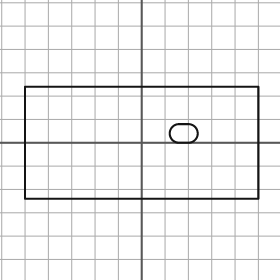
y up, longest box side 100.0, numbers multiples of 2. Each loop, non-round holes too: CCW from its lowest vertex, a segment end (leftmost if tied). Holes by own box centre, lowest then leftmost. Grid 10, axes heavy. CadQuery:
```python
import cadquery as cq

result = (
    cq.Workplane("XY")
    .moveTo(-50.0, -24.0)
    .lineTo(50.0, -24.0)
    .lineTo(50.0, 24.0)
    .lineTo(-50.0, 24.0)
    .close()
    .moveTo(16.0, 0.0)
    .lineTo(20.0, 0.0)
    .threePointArc((24.0, 4.0), (20.0, 8.0))
    .lineTo(16.0, 8.0)
    .threePointArc((12.0, 4.0), (16.0, 0.0))
    .close()
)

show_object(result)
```